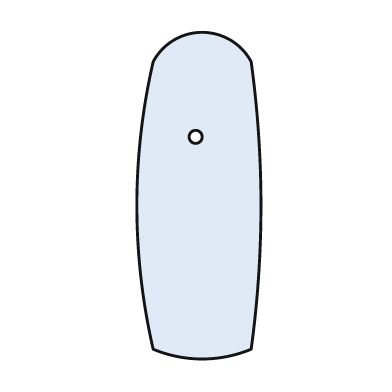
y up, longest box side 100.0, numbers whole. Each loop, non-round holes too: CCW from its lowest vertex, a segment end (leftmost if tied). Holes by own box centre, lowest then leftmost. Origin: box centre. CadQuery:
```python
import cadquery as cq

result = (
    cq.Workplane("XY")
    .moveTo(-14.0, -47.0)
    .threePointArc((1.0, -50.0), (16.0, -47.0))
    .threePointArc((19.0, -3.0), (16.0, 41.0))
    .threePointArc((1.0, 50.0), (-14.0, 41.0))
    .threePointArc((-19.0, -3.0), (-14.0, -47.0))
    .close()
    .moveTo(-1.0, 18.0)
    .circle(2.0)
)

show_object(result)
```